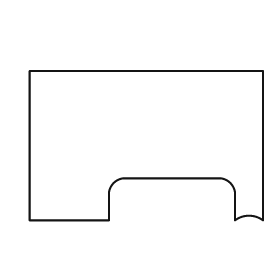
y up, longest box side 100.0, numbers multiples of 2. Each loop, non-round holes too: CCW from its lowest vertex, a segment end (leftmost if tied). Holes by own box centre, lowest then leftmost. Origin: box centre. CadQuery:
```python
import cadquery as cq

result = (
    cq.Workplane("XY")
    .moveTo(-50.0, -32.0)
    .lineTo(-16.0, -32.0)
    .lineTo(-16.0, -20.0)
    .threePointArc((-14.0, -16.0), (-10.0, -14.0))
    .lineTo(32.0, -14.0)
    .threePointArc((36.0, -16.0), (38.0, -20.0))
    .lineTo(38.0, -32.0)
    .threePointArc((44.0, -30.0), (50.0, -32.0))
    .lineTo(50.0, 32.0)
    .lineTo(-50.0, 32.0)
    .close()
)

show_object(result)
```